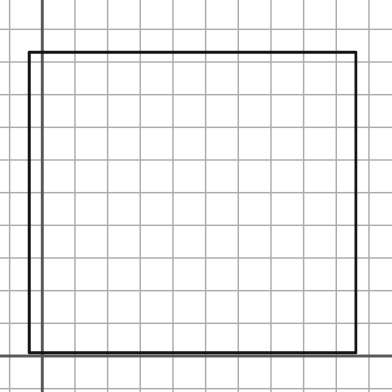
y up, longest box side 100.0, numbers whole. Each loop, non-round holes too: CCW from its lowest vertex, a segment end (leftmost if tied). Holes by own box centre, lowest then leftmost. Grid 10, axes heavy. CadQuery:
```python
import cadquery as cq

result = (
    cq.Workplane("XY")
    .moveTo(-4.0, 1.0)
    .lineTo(96.0, 1.0)
    .lineTo(96.0, 93.0)
    .lineTo(-4.0, 93.0)
    .close()
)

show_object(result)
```